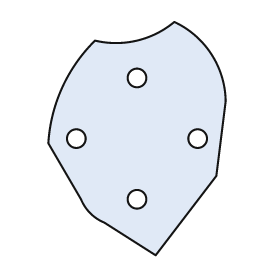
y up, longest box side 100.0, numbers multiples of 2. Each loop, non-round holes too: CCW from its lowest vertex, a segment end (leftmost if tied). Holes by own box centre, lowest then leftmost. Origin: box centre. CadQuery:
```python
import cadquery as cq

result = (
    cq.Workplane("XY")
    .moveTo(8.0, -50.0)
    .lineTo(34.0, -16.0)
    .lineTo(38.0, 16.0)
    .threePointArc((32.0, 36.0), (16.0, 50.0))
    .threePointArc((0.0, 42.0), (-18.0, 42.0))
    .threePointArc((-32.0, 22.0), (-38.0, -2.0))
    .lineTo(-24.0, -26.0)
    .threePointArc((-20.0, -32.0), (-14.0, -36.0))
    .close()
    .moveTo(0.0, -26.0)
    .circle(4.0)
    .moveTo(-26.0, 0.0)
    .circle(4.0)
    .moveTo(26.0, 0.0)
    .circle(4.0)
    .moveTo(0.0, 26.0)
    .circle(4.0)
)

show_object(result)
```